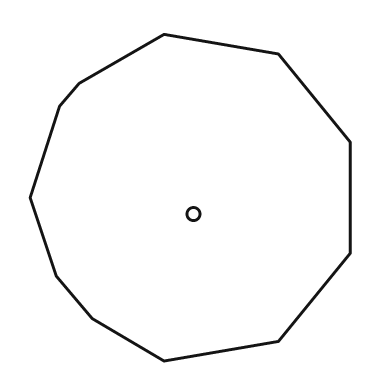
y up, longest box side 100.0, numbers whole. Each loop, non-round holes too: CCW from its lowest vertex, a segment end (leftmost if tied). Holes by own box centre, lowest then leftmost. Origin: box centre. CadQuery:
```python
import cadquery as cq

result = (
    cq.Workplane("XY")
    .moveTo(-8.0, -50.0)
    .lineTo(27.0, -44.0)
    .lineTo(49.0, -17.0)
    .lineTo(49.0, 17.0)
    .lineTo(27.0, 44.0)
    .lineTo(-8.0, 50.0)
    .lineTo(-34.0, 35.0)
    .lineTo(-40.0, 28.0)
    .lineTo(-49.0, 0.0)
    .lineTo(-41.0, -24.0)
    .lineTo(-30.0, -37.0)
    .close()
    .moveTo(1.0, -5.0)
    .circle(2.0)
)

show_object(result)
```